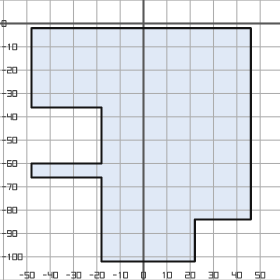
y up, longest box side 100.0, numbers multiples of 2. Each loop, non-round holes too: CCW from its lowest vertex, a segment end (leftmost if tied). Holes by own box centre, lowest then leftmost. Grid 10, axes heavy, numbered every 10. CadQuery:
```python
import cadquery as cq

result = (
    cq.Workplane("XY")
    .moveTo(-18.0, -102.0)
    .lineTo(22.0, -102.0)
    .lineTo(22.0, -84.0)
    .lineTo(46.0, -84.0)
    .lineTo(46.0, -2.0)
    .lineTo(-48.0, -2.0)
    .lineTo(-48.0, -36.0)
    .lineTo(-18.0, -36.0)
    .lineTo(-18.0, -60.0)
    .lineTo(-48.0, -60.0)
    .lineTo(-48.0, -66.0)
    .lineTo(-18.0, -66.0)
    .close()
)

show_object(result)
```